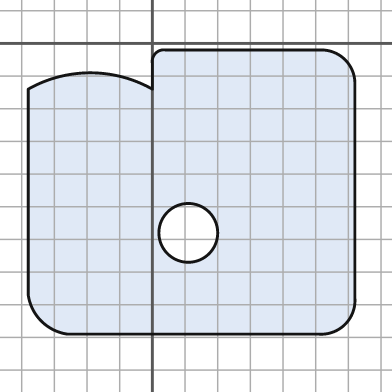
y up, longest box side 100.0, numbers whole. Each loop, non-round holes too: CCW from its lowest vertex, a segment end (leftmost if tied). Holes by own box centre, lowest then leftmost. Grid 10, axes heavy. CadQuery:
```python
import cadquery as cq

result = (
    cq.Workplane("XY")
    .moveTo(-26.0, -89.0)
    .lineTo(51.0, -89.0)
    .threePointArc((59.0, -86.0), (62.0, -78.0))
    .lineTo(62.0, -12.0)
    .threePointArc((59.0, -5.0), (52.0, -2.0))
    .lineTo(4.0, -2.0)
    .threePointArc((1.0, -3.0), (0.0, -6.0))
    .lineTo(0.0, -14.0)
    .threePointArc((-19.0, -9.0), (-38.0, -14.0))
    .lineTo(-38.0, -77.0)
    .threePointArc((-34.0, -85.0), (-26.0, -89.0))
    .close()
    .moveTo(11.0, -58.0)
    .circle(9.0)
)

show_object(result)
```